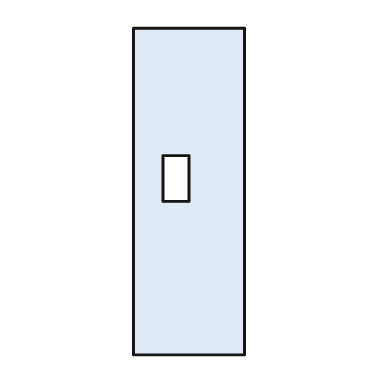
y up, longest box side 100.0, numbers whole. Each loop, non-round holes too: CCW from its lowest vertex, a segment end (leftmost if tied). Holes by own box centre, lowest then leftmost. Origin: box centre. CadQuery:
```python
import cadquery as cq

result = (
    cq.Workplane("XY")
    .moveTo(-17.0, -50.0)
    .lineTo(17.0, -50.0)
    .lineTo(17.0, 50.0)
    .lineTo(-17.0, 50.0)
    .close()
    .moveTo(-8.0, -3.0)
    .lineTo(0.0, -3.0)
    .lineTo(0.0, 11.0)
    .lineTo(-8.0, 11.0)
    .close()
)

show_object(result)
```